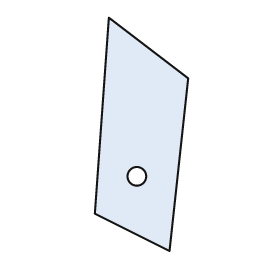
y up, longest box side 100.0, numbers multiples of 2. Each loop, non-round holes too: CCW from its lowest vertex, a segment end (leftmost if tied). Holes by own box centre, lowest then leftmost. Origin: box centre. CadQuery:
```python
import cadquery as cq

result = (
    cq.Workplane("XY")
    .moveTo(12.0, -50.0)
    .lineTo(20.0, 24.0)
    .lineTo(-14.0, 50.0)
    .lineTo(-20.0, -34.0)
    .close()
    .moveTo(-2.0, -18.0)
    .circle(4.0)
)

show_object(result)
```